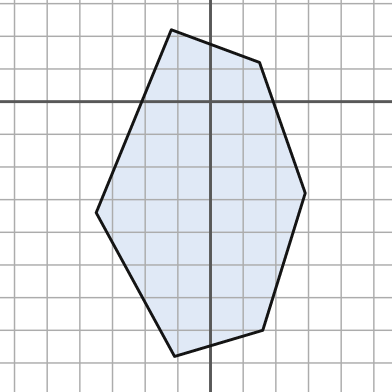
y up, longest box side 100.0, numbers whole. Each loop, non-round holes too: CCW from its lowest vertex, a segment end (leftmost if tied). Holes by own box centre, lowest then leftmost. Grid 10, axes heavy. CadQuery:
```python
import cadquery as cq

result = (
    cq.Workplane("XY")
    .moveTo(-11.0, -78.0)
    .lineTo(16.0, -70.0)
    .lineTo(29.0, -28.0)
    .lineTo(15.0, 12.0)
    .lineTo(-12.0, 22.0)
    .lineTo(-35.0, -34.0)
    .close()
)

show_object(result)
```